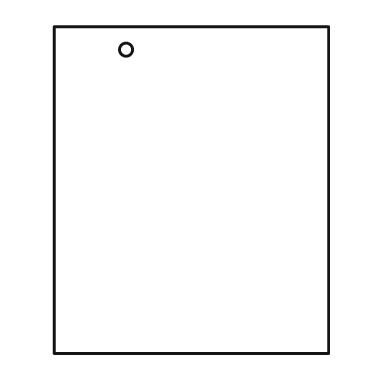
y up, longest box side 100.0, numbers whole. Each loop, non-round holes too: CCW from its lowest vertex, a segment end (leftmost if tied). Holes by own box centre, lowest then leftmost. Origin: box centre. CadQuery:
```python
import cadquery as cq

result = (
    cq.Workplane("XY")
    .moveTo(-42.0, -50.0)
    .lineTo(42.0, -50.0)
    .lineTo(42.0, 50.0)
    .lineTo(-42.0, 50.0)
    .close()
    .moveTo(-20.0, 43.0)
    .circle(2.0)
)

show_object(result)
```